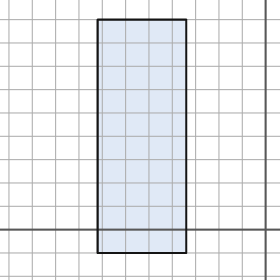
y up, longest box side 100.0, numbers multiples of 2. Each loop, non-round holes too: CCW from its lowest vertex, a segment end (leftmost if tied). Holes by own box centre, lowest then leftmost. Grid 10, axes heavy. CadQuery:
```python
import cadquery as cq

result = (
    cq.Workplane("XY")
    .moveTo(-72.0, -10.0)
    .lineTo(-34.0, -10.0)
    .lineTo(-34.0, 90.0)
    .lineTo(-72.0, 90.0)
    .close()
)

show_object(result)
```